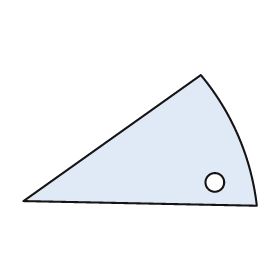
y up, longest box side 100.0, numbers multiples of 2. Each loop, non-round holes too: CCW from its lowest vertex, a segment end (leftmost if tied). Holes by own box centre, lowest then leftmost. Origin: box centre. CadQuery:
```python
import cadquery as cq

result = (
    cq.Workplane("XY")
    .moveTo(50.0, -28.0)
    .threePointArc((42.0, 2.0), (26.0, 28.0))
    .lineTo(-50.0, -26.0)
    .close()
    .moveTo(32.0, -18.0)
    .circle(4.0)
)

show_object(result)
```